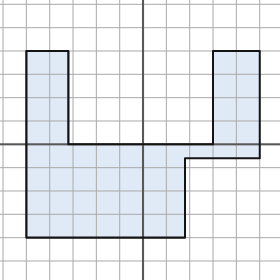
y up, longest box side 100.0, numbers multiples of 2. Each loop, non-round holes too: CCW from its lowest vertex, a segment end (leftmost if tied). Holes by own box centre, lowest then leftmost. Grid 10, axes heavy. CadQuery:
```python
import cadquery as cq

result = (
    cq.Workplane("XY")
    .moveTo(-50.0, -40.0)
    .lineTo(18.0, -40.0)
    .lineTo(18.0, -6.0)
    .lineTo(50.0, -6.0)
    .lineTo(50.0, 40.0)
    .lineTo(30.0, 40.0)
    .lineTo(30.0, 0.0)
    .lineTo(-32.0, 0.0)
    .lineTo(-32.0, 40.0)
    .lineTo(-50.0, 40.0)
    .close()
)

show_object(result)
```